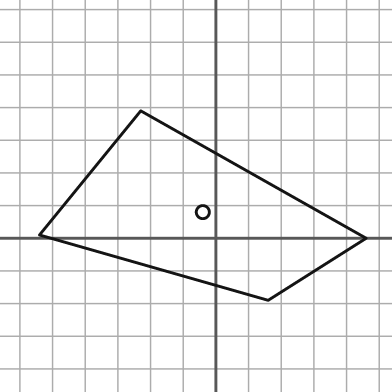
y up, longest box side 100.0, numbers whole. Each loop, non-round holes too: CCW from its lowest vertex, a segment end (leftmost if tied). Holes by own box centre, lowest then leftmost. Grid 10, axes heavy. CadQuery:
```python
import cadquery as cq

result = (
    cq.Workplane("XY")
    .moveTo(16.0, -19.0)
    .lineTo(46.0, 0.0)
    .lineTo(-23.0, 39.0)
    .lineTo(-54.0, 1.0)
    .close()
    .moveTo(-4.0, 8.0)
    .circle(2.0)
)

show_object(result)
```